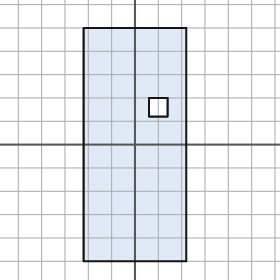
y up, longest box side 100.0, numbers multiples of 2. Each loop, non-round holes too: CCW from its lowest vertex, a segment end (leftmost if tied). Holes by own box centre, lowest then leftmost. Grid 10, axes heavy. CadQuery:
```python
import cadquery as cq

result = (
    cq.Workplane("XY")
    .moveTo(-22.0, -50.0)
    .lineTo(22.0, -50.0)
    .lineTo(22.0, 50.0)
    .lineTo(-22.0, 50.0)
    .close()
    .moveTo(6.0, 12.0)
    .lineTo(14.0, 12.0)
    .lineTo(14.0, 20.0)
    .lineTo(6.0, 20.0)
    .close()
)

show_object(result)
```